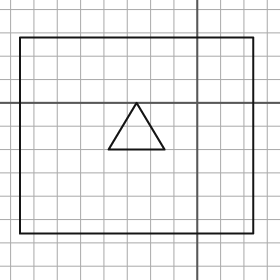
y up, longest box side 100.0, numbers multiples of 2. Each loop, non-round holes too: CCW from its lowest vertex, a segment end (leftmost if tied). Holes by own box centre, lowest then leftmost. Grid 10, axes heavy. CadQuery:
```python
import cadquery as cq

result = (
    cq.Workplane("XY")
    .moveTo(-76.0, -56.0)
    .lineTo(24.0, -56.0)
    .lineTo(24.0, 28.0)
    .lineTo(-76.0, 28.0)
    .close()
    .moveTo(-38.0, -20.0)
    .lineTo(-14.0, -20.0)
    .lineTo(-26.0, 0.0)
    .close()
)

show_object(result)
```